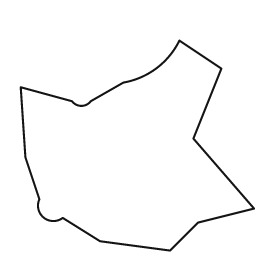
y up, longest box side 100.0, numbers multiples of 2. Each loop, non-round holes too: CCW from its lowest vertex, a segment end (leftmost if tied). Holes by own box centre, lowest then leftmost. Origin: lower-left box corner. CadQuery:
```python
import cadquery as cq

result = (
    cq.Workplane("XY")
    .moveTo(64.0, 0.0)
    .lineTo(76.0, 12.0)
    .lineTo(100.0, 18.0)
    .lineTo(74.0, 48.0)
    .lineTo(86.0, 78.0)
    .lineTo(68.0, 90.0)
    .threePointArc((58.0, 78.0), (44.0, 72.0))
    .lineTo(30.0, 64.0)
    .threePointArc((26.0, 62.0), (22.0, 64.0))
    .lineTo(0.0, 70.0)
    .lineTo(2.0, 40.0)
    .lineTo(8.0, 22.0)
    .threePointArc((10.0, 14.0), (18.0, 14.0))
    .lineTo(34.0, 4.0)
    .close()
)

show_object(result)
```